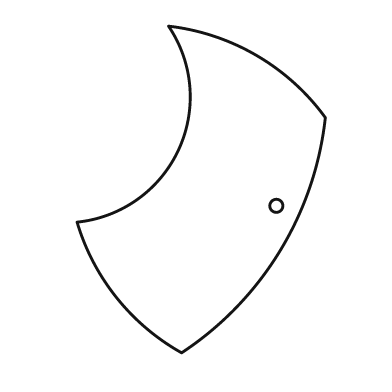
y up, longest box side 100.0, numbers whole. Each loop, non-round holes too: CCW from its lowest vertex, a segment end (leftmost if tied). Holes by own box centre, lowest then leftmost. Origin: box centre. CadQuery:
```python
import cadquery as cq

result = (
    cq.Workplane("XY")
    .moveTo(-6.0, -50.0)
    .threePointArc((24.0, -19.0), (38.0, 22.0))
    .threePointArc((17.0, 41.0), (-10.0, 50.0))
    .threePointArc((-7.0, 12.0), (-38.0, -10.0))
    .threePointArc((-26.0, -33.0), (-6.0, -50.0))
    .close()
    .moveTo(23.0, -5.0)
    .circle(2.0)
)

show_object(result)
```